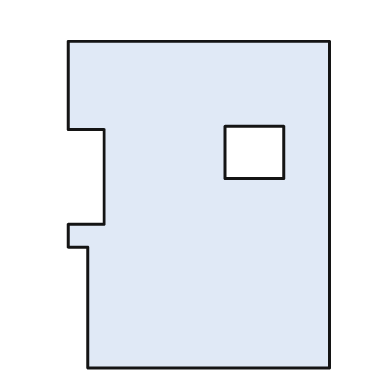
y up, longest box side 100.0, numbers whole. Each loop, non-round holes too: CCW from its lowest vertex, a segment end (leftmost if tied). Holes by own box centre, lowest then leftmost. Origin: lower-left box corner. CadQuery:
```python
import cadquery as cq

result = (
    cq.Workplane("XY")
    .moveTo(6.0, 0.0)
    .lineTo(80.0, 0.0)
    .lineTo(80.0, 100.0)
    .lineTo(0.0, 100.0)
    .lineTo(0.0, 73.0)
    .lineTo(11.0, 73.0)
    .lineTo(11.0, 44.0)
    .lineTo(0.0, 44.0)
    .lineTo(0.0, 37.0)
    .lineTo(6.0, 37.0)
    .close()
    .moveTo(48.0, 58.0)
    .lineTo(66.0, 58.0)
    .lineTo(66.0, 74.0)
    .lineTo(48.0, 74.0)
    .close()
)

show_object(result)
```